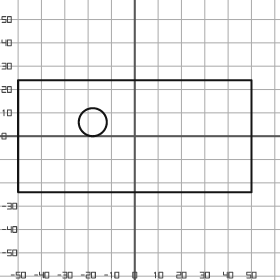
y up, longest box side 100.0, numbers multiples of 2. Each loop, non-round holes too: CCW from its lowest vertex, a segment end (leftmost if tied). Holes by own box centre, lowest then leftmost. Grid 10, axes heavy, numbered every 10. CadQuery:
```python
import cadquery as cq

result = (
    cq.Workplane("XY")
    .moveTo(-50.0, -24.0)
    .lineTo(50.0, -24.0)
    .lineTo(50.0, 24.0)
    .lineTo(-50.0, 24.0)
    .close()
    .moveTo(-18.0, 6.0)
    .circle(6.0)
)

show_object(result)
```